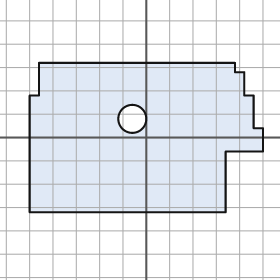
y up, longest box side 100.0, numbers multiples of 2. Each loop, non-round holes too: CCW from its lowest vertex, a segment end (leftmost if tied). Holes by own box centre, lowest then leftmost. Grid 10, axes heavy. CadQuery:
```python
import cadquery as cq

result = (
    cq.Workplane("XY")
    .moveTo(-50.0, -32.0)
    .lineTo(34.0, -32.0)
    .lineTo(34.0, -6.0)
    .lineTo(50.0, -6.0)
    .lineTo(50.0, 4.0)
    .lineTo(46.0, 4.0)
    .lineTo(46.0, 18.0)
    .lineTo(42.0, 18.0)
    .lineTo(42.0, 28.0)
    .lineTo(38.0, 28.0)
    .lineTo(38.0, 32.0)
    .lineTo(-46.0, 32.0)
    .lineTo(-46.0, 18.0)
    .lineTo(-50.0, 18.0)
    .close()
    .moveTo(-6.0, 8.0)
    .circle(6.0)
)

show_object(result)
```